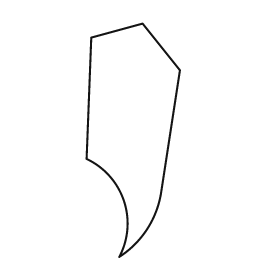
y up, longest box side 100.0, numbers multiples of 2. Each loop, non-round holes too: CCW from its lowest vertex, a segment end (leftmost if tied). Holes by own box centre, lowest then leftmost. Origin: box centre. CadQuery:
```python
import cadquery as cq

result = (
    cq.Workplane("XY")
    .moveTo(-6.0, -50.0)
    .threePointArc((6.0, -38.0), (12.0, -22.0))
    .lineTo(20.0, 30.0)
    .lineTo(4.0, 50.0)
    .lineTo(-18.0, 44.0)
    .lineTo(-20.0, -8.0)
    .threePointArc((-4.0, -26.0), (-6.0, -50.0))
    .close()
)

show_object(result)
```